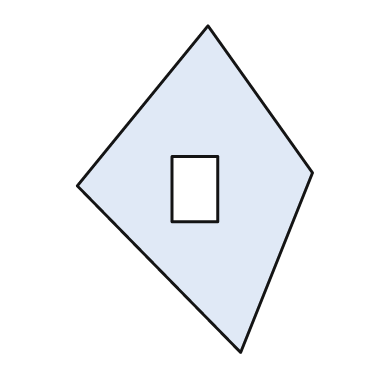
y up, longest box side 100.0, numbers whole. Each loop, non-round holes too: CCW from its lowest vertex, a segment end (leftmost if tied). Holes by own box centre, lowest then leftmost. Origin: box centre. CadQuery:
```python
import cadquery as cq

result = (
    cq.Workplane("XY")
    .moveTo(14.0, -50.0)
    .lineTo(36.0, 5.0)
    .lineTo(4.0, 50.0)
    .lineTo(-36.0, 1.0)
    .close()
    .moveTo(-7.0, -10.0)
    .lineTo(7.0, -10.0)
    .lineTo(7.0, 10.0)
    .lineTo(-7.0, 10.0)
    .close()
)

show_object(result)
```